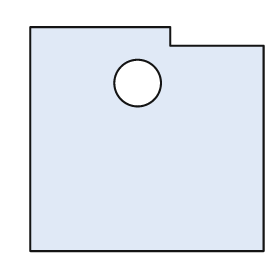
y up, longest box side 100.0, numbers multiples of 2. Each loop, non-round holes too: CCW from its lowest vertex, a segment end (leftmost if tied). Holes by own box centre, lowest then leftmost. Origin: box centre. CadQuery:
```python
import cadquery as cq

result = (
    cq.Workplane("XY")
    .moveTo(-50.0, -48.0)
    .lineTo(50.0, -48.0)
    .lineTo(50.0, 40.0)
    .lineTo(10.0, 40.0)
    .lineTo(10.0, 48.0)
    .lineTo(-50.0, 48.0)
    .close()
    .moveTo(-4.0, 24.0)
    .circle(10.0)
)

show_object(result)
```